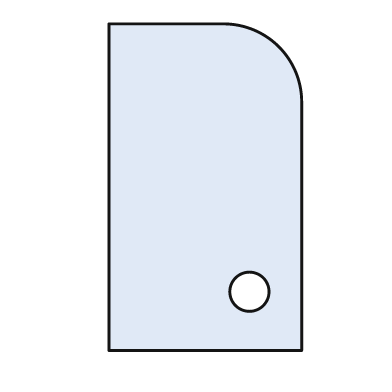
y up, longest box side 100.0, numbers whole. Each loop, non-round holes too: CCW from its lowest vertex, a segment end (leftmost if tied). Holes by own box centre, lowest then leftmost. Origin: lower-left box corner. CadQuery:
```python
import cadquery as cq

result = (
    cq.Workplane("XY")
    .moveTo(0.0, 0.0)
    .lineTo(59.0, 0.0)
    .lineTo(59.0, 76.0)
    .threePointArc((52.0, 93.0), (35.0, 100.0))
    .lineTo(0.0, 100.0)
    .close()
    .moveTo(43.0, 18.0)
    .circle(6.0)
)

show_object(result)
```